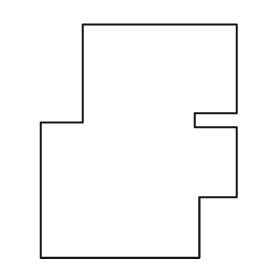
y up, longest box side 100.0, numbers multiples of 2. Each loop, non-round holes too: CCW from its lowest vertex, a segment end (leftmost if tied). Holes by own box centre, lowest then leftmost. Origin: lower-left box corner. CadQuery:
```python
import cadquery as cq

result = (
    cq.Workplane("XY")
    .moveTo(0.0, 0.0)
    .lineTo(68.0, 0.0)
    .lineTo(68.0, 26.0)
    .lineTo(84.0, 26.0)
    .lineTo(84.0, 56.0)
    .lineTo(66.0, 56.0)
    .lineTo(66.0, 62.0)
    .lineTo(84.0, 62.0)
    .lineTo(84.0, 100.0)
    .lineTo(18.0, 100.0)
    .lineTo(18.0, 58.0)
    .lineTo(0.0, 58.0)
    .close()
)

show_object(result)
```